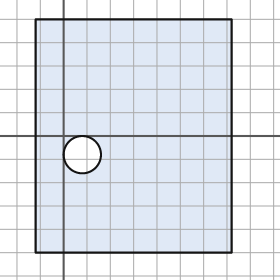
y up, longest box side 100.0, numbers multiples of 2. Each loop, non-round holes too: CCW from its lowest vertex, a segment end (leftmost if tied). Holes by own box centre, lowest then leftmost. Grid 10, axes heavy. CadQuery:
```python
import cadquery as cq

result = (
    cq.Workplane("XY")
    .moveTo(-12.0, -50.0)
    .lineTo(72.0, -50.0)
    .lineTo(72.0, 50.0)
    .lineTo(-12.0, 50.0)
    .close()
    .moveTo(8.0, -8.0)
    .circle(8.0)
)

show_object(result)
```